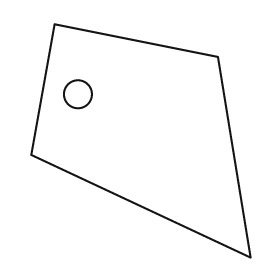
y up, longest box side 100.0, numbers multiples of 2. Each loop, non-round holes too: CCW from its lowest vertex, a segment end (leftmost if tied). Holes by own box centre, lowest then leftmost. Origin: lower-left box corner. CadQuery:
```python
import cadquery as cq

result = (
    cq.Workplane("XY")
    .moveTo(94.0, 0.0)
    .lineTo(80.0, 86.0)
    .lineTo(10.0, 100.0)
    .lineTo(0.0, 44.0)
    .close()
    .moveTo(20.0, 70.0)
    .circle(6.0)
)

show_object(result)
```